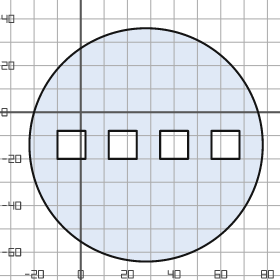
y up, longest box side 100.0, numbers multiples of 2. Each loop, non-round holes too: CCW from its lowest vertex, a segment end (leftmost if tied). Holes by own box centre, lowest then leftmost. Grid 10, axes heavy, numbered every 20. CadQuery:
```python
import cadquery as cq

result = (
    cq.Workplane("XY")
    .moveTo(28.0, -14.0)
    .circle(50.0)
    .moveTo(-10.0, -20.0)
    .lineTo(2.0, -20.0)
    .lineTo(2.0, -8.0)
    .lineTo(-10.0, -8.0)
    .close()
    .moveTo(12.0, -20.0)
    .lineTo(24.0, -20.0)
    .lineTo(24.0, -8.0)
    .lineTo(12.0, -8.0)
    .close()
    .moveTo(34.0, -20.0)
    .lineTo(46.0, -20.0)
    .lineTo(46.0, -8.0)
    .lineTo(34.0, -8.0)
    .close()
    .moveTo(56.0, -20.0)
    .lineTo(68.0, -20.0)
    .lineTo(68.0, -8.0)
    .lineTo(56.0, -8.0)
    .close()
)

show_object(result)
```